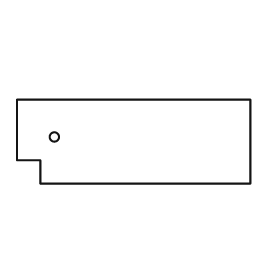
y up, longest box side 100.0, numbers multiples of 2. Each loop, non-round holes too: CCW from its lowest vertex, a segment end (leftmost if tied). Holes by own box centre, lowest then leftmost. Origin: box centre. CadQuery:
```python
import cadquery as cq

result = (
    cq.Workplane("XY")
    .moveTo(-40.0, -18.0)
    .lineTo(50.0, -18.0)
    .lineTo(50.0, 18.0)
    .lineTo(-50.0, 18.0)
    .lineTo(-50.0, -8.0)
    .lineTo(-40.0, -8.0)
    .close()
    .moveTo(-34.0, 2.0)
    .circle(2.0)
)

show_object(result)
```